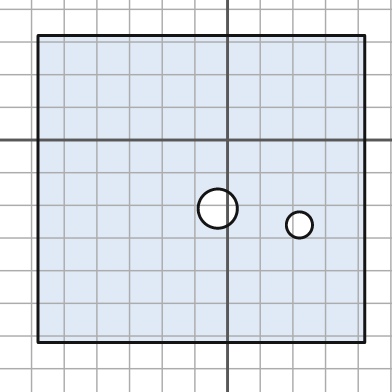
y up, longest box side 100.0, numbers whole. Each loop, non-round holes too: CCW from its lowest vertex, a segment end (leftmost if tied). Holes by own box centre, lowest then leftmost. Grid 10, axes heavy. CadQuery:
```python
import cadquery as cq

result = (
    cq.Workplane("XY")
    .moveTo(-58.0, -62.0)
    .lineTo(42.0, -62.0)
    .lineTo(42.0, 32.0)
    .lineTo(-58.0, 32.0)
    .close()
    .moveTo(22.0, -26.0)
    .circle(4.0)
    .moveTo(-3.0, -21.0)
    .circle(6.0)
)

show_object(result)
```